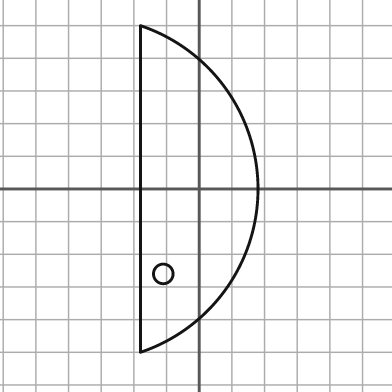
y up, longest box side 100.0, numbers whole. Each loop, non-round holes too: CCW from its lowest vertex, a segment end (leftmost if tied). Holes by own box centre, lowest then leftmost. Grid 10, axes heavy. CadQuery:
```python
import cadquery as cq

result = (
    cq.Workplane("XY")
    .moveTo(-18.0, -50.0)
    .threePointArc((18.0, 0.0), (-18.0, 50.0))
    .close()
    .moveTo(-11.0, -26.0)
    .circle(3.0)
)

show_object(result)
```